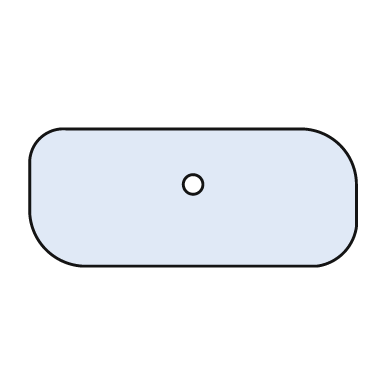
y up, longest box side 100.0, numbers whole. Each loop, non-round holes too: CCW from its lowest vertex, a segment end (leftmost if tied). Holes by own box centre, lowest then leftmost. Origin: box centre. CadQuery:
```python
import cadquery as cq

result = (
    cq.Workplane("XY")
    .moveTo(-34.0, -21.0)
    .lineTo(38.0, -21.0)
    .threePointArc((46.0, -17.0), (50.0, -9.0))
    .lineTo(50.0, 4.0)
    .threePointArc((45.0, 16.0), (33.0, 21.0))
    .lineTo(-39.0, 21.0)
    .threePointArc((-47.0, 18.0), (-50.0, 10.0))
    .lineTo(-50.0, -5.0)
    .threePointArc((-45.0, -16.0), (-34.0, -21.0))
    .close()
    .moveTo(0.0, 4.0)
    .circle(3.0)
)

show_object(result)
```